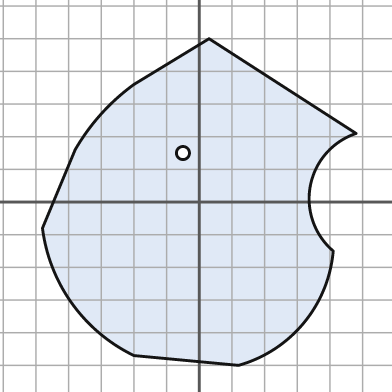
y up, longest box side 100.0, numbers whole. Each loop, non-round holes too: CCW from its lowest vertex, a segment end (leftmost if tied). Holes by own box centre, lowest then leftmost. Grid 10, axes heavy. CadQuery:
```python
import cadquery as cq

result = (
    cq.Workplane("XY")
    .moveTo(12.0, -50.0)
    .threePointArc((32.0, -37.0), (41.0, -15.0))
    .threePointArc((34.0, 5.0), (48.0, 21.0))
    .lineTo(3.0, 50.0)
    .lineTo(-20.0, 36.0)
    .threePointArc((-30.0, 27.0), (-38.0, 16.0))
    .lineTo(-48.0, -8.0)
    .threePointArc((-39.0, -31.0), (-20.0, -47.0))
    .close()
    .moveTo(-5.0, 15.0)
    .circle(2.0)
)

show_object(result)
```